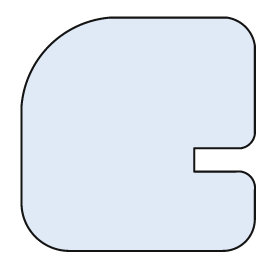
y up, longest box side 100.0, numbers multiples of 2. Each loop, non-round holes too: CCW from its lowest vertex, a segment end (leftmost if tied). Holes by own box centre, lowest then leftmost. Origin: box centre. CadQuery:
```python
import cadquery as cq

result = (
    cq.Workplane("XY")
    .moveTo(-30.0, -50.0)
    .lineTo(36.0, -50.0)
    .threePointArc((46.0, -46.0), (50.0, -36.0))
    .lineTo(50.0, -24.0)
    .threePointArc((48.0, -18.0), (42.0, -16.0))
    .lineTo(24.0, -16.0)
    .lineTo(24.0, -6.0)
    .lineTo(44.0, -6.0)
    .threePointArc((48.0, -4.0), (50.0, 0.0))
    .lineTo(50.0, 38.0)
    .threePointArc((46.0, 46.0), (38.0, 50.0))
    .lineTo(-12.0, 50.0)
    .threePointArc((-38.0, 38.0), (-50.0, 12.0))
    .lineTo(-50.0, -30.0)
    .threePointArc((-44.0, -44.0), (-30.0, -50.0))
    .close()
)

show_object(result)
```